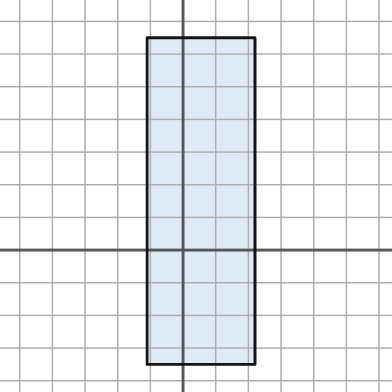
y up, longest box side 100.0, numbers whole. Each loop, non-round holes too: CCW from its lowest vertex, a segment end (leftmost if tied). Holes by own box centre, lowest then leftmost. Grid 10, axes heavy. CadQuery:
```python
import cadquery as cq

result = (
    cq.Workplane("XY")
    .moveTo(-11.0, -35.0)
    .lineTo(22.0, -35.0)
    .lineTo(22.0, 65.0)
    .lineTo(-11.0, 65.0)
    .close()
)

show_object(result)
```